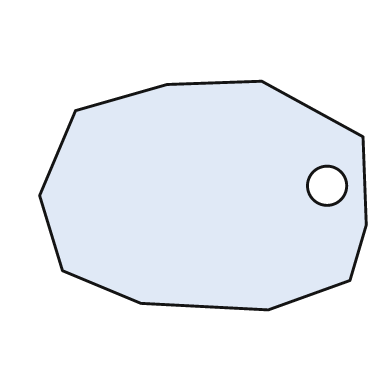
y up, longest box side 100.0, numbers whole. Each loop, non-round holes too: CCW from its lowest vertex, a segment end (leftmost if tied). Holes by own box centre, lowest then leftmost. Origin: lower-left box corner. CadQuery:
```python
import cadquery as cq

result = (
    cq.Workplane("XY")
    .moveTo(70.0, 0.0)
    .lineTo(95.0, 9.0)
    .lineTo(100.0, 26.0)
    .lineTo(99.0, 53.0)
    .lineTo(68.0, 70.0)
    .lineTo(39.0, 69.0)
    .lineTo(11.0, 61.0)
    .lineTo(0.0, 35.0)
    .lineTo(7.0, 12.0)
    .lineTo(31.0, 2.0)
    .close()
    .moveTo(88.0, 38.0)
    .circle(6.0)
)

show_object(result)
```